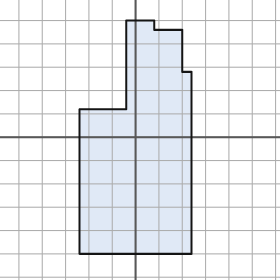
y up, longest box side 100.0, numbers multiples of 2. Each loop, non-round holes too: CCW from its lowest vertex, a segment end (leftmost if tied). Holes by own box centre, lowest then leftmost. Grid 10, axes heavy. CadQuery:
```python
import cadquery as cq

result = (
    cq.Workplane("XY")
    .moveTo(-24.0, -50.0)
    .lineTo(24.0, -50.0)
    .lineTo(24.0, 28.0)
    .lineTo(20.0, 28.0)
    .lineTo(20.0, 46.0)
    .lineTo(8.0, 46.0)
    .lineTo(8.0, 50.0)
    .lineTo(-4.0, 50.0)
    .lineTo(-4.0, 12.0)
    .lineTo(-24.0, 12.0)
    .close()
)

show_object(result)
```